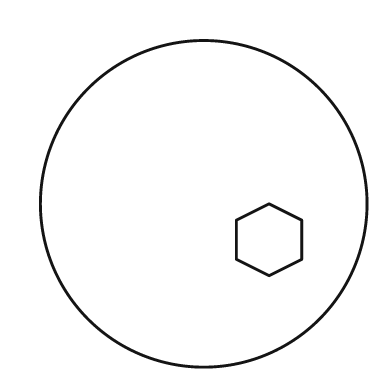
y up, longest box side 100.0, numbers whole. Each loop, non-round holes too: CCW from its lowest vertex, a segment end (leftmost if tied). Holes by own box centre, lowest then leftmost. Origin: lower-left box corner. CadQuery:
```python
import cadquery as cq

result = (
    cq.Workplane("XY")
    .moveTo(50.0, 50.0)
    .circle(50.0)
    .moveTo(70.0, 28.0)
    .lineTo(80.0, 33.0)
    .lineTo(80.0, 45.0)
    .lineTo(70.0, 50.0)
    .lineTo(60.0, 45.0)
    .lineTo(60.0, 33.0)
    .close()
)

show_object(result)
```